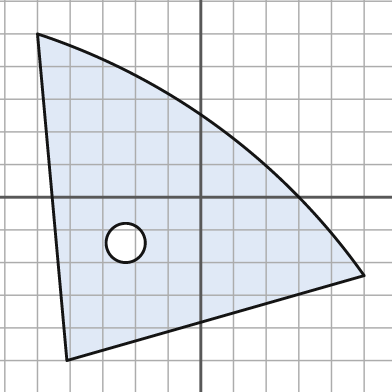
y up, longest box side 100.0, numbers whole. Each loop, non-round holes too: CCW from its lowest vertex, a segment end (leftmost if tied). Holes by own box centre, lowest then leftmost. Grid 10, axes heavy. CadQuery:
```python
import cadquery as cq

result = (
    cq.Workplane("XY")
    .moveTo(-41.0, -50.0)
    .lineTo(50.0, -24.0)
    .threePointArc((6.0, 21.0), (-50.0, 50.0))
    .close()
    .moveTo(-23.0, -14.0)
    .circle(6.0)
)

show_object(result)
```